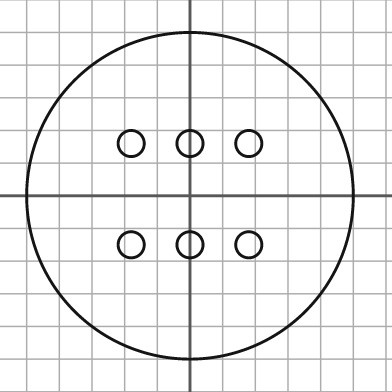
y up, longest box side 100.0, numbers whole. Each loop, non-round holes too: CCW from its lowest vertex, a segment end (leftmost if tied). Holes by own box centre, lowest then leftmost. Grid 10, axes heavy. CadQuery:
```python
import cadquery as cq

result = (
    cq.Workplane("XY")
    .moveTo(0.0, 0.0)
    .circle(50.0)
    .moveTo(-18.0, -15.0)
    .circle(4.0)
    .moveTo(0.0, -15.0)
    .circle(4.0)
    .moveTo(18.0, -15.0)
    .circle(4.0)
    .moveTo(-18.0, 16.0)
    .circle(4.0)
    .moveTo(0.0, 16.0)
    .circle(4.0)
    .moveTo(18.0, 16.0)
    .circle(4.0)
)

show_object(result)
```